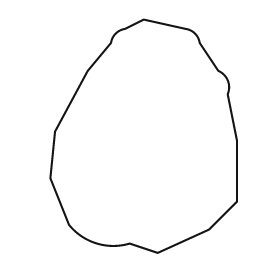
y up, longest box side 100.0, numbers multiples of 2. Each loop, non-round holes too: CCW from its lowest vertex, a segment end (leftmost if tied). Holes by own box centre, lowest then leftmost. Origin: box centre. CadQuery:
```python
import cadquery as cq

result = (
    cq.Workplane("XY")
    .moveTo(6.0, -50.0)
    .lineTo(28.0, -40.0)
    .lineTo(40.0, -28.0)
    .lineTo(40.0, -2.0)
    .lineTo(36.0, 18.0)
    .threePointArc((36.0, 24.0), (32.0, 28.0))
    .lineTo(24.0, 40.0)
    .threePointArc((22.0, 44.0), (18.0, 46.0))
    .lineTo(0.0, 50.0)
    .lineTo(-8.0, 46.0)
    .threePointArc((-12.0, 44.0), (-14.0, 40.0))
    .lineTo(-24.0, 28.0)
    .lineTo(-38.0, 2.0)
    .lineTo(-40.0, -18.0)
    .lineTo(-32.0, -38.0)
    .threePointArc((-20.0, -46.0), (-6.0, -46.0))
    .close()
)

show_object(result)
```